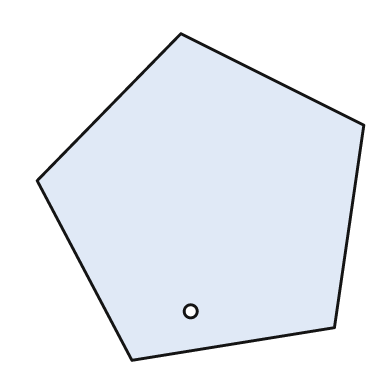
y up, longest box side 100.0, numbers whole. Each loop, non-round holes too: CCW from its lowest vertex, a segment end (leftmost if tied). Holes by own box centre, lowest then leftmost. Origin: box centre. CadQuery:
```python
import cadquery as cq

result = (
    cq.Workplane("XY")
    .moveTo(-21.0, -50.0)
    .lineTo(41.0, -40.0)
    .lineTo(50.0, 22.0)
    .lineTo(-6.0, 50.0)
    .lineTo(-50.0, 5.0)
    .close()
    .moveTo(-3.0, -35.0)
    .circle(2.0)
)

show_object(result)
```